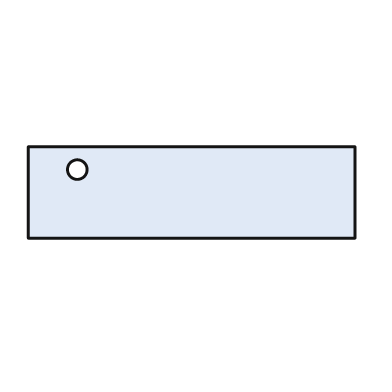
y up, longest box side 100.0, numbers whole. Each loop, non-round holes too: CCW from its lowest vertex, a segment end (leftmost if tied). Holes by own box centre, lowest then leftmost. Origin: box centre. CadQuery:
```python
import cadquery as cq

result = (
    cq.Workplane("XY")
    .moveTo(-50.0, -14.0)
    .lineTo(50.0, -14.0)
    .lineTo(50.0, 14.0)
    .lineTo(-50.0, 14.0)
    .close()
    .moveTo(-35.0, 7.0)
    .circle(3.0)
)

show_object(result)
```